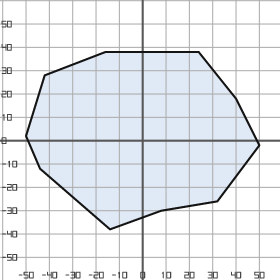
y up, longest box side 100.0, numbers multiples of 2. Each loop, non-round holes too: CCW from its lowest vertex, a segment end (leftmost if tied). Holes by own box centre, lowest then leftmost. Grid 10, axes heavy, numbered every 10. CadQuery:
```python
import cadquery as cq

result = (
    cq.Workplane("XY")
    .moveTo(-14.0, -38.0)
    .lineTo(8.0, -30.0)
    .lineTo(32.0, -26.0)
    .lineTo(50.0, -2.0)
    .lineTo(40.0, 18.0)
    .lineTo(24.0, 38.0)
    .lineTo(-16.0, 38.0)
    .lineTo(-42.0, 28.0)
    .lineTo(-50.0, 2.0)
    .lineTo(-44.0, -12.0)
    .close()
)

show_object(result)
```